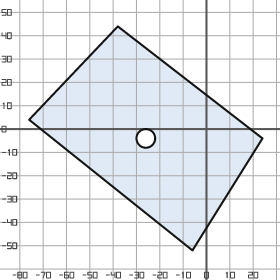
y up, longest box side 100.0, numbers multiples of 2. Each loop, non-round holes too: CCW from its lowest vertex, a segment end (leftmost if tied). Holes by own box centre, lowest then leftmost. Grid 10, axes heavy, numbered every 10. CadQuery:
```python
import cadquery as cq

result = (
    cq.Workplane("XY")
    .moveTo(-6.0, -52.0)
    .lineTo(24.0, -4.0)
    .lineTo(-38.0, 44.0)
    .lineTo(-76.0, 4.0)
    .close()
    .moveTo(-26.0, -4.0)
    .circle(4.0)
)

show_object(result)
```